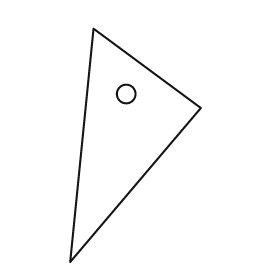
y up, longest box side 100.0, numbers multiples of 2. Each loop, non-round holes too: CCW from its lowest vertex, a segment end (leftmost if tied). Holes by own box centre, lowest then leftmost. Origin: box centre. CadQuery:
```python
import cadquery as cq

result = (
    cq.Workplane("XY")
    .moveTo(-28.0, -50.0)
    .lineTo(28.0, 16.0)
    .lineTo(-18.0, 50.0)
    .close()
    .moveTo(-4.0, 22.0)
    .circle(4.0)
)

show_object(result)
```